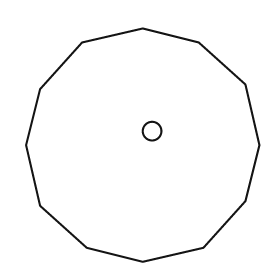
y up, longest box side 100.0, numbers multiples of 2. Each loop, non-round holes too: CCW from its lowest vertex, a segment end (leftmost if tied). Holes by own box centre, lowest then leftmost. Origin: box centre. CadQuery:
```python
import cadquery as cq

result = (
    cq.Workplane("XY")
    .moveTo(0.0, -50.0)
    .lineTo(26.0, -44.0)
    .lineTo(44.0, -24.0)
    .lineTo(50.0, 0.0)
    .lineTo(44.0, 26.0)
    .lineTo(24.0, 44.0)
    .lineTo(0.0, 50.0)
    .lineTo(-26.0, 44.0)
    .lineTo(-44.0, 24.0)
    .lineTo(-50.0, 0.0)
    .lineTo(-44.0, -26.0)
    .lineTo(-24.0, -44.0)
    .close()
    .moveTo(4.0, 6.0)
    .circle(4.0)
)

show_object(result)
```